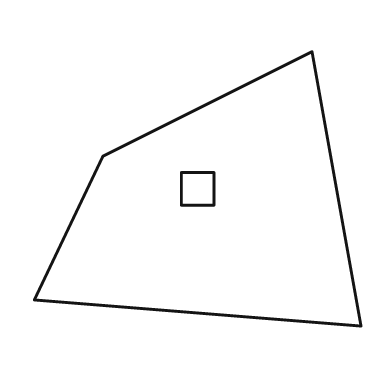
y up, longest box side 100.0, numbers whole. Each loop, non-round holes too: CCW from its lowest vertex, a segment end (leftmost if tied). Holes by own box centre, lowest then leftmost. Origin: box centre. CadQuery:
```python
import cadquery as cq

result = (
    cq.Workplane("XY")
    .moveTo(50.0, -42.0)
    .lineTo(35.0, 42.0)
    .lineTo(-29.0, 10.0)
    .lineTo(-50.0, -34.0)
    .close()
    .moveTo(-5.0, -5.0)
    .lineTo(5.0, -5.0)
    .lineTo(5.0, 5.0)
    .lineTo(-5.0, 5.0)
    .close()
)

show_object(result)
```